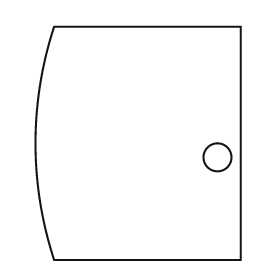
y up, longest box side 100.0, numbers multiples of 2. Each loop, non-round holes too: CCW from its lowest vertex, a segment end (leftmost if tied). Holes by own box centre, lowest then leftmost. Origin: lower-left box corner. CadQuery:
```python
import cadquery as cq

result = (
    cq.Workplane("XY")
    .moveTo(8.0, 0.0)
    .lineTo(88.0, 0.0)
    .lineTo(88.0, 100.0)
    .lineTo(8.0, 100.0)
    .threePointArc((0.0, 50.0), (8.0, 0.0))
    .close()
    .moveTo(78.0, 44.0)
    .circle(6.0)
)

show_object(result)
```